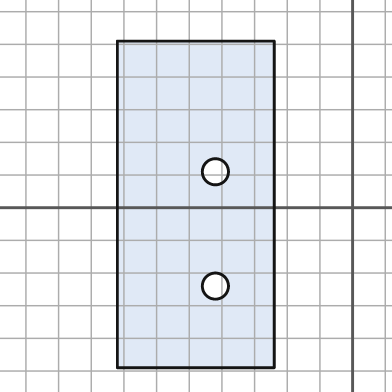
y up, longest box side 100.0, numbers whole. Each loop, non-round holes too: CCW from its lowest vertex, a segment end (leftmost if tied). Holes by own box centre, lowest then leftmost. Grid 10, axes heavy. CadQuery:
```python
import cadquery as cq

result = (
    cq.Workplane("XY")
    .moveTo(-72.0, -49.0)
    .lineTo(-24.0, -49.0)
    .lineTo(-24.0, 51.0)
    .lineTo(-72.0, 51.0)
    .close()
    .moveTo(-42.0, -24.0)
    .circle(4.0)
    .moveTo(-42.0, 11.0)
    .circle(4.0)
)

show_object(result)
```